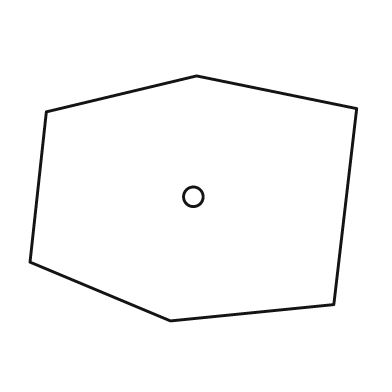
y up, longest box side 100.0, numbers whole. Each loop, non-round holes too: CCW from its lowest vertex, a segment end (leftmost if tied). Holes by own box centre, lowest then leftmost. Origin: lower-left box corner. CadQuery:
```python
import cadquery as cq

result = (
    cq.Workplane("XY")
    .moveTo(43.0, 0.0)
    .lineTo(93.0, 5.0)
    .lineTo(100.0, 65.0)
    .lineTo(51.0, 75.0)
    .lineTo(5.0, 64.0)
    .lineTo(0.0, 18.0)
    .close()
    .moveTo(50.0, 38.0)
    .circle(3.0)
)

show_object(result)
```